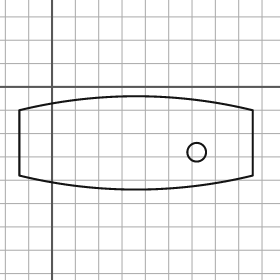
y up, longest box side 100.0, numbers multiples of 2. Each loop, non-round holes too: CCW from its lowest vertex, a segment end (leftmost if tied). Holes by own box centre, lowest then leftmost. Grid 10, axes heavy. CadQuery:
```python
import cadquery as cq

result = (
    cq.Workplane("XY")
    .moveTo(-14.0, -38.0)
    .threePointArc((36.0, -44.0), (86.0, -38.0))
    .lineTo(86.0, -10.0)
    .threePointArc((36.0, -4.0), (-14.0, -10.0))
    .close()
    .moveTo(62.0, -28.0)
    .circle(4.0)
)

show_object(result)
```